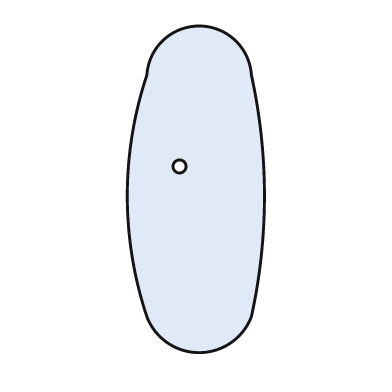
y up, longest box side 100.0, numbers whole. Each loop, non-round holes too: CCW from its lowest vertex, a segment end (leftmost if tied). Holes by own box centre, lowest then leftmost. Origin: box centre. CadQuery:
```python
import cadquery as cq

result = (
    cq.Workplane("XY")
    .moveTo(-15.0, -39.0)
    .threePointArc((1.0, -50.0), (17.0, -39.0))
    .threePointArc((21.0, -2.0), (17.0, 35.0))
    .threePointArc((1.0, 50.0), (-15.0, 35.0))
    .threePointArc((-21.0, -2.0), (-15.0, -39.0))
    .close()
    .moveTo(-5.0, 7.0)
    .circle(2.0)
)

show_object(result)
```